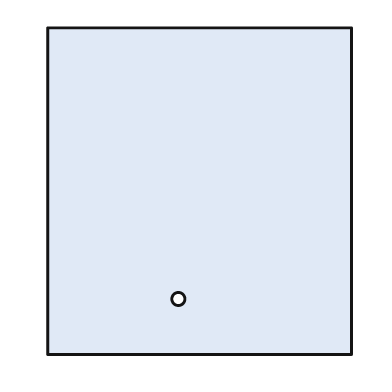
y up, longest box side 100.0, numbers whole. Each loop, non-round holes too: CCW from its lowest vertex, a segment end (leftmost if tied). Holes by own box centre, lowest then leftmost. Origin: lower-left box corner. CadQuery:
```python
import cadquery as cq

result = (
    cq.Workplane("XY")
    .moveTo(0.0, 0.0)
    .lineTo(93.0, 0.0)
    .lineTo(93.0, 100.0)
    .lineTo(0.0, 100.0)
    .close()
    .moveTo(40.0, 17.0)
    .circle(2.0)
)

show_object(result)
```